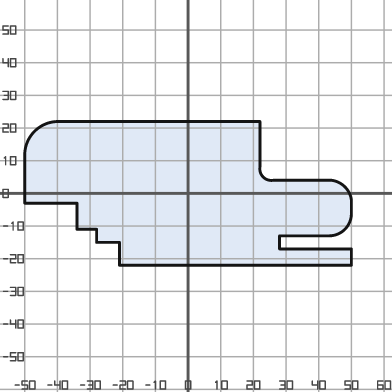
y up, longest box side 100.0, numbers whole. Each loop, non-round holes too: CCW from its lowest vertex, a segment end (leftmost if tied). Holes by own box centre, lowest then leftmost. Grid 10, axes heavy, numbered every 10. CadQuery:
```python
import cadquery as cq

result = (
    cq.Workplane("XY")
    .moveTo(-21.0, -22.0)
    .lineTo(50.0, -22.0)
    .lineTo(50.0, -17.0)
    .lineTo(28.0, -17.0)
    .lineTo(28.0, -13.0)
    .lineTo(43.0, -13.0)
    .threePointArc((48.0, -11.0), (50.0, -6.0))
    .lineTo(50.0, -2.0)
    .threePointArc((48.0, 2.0), (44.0, 4.0))
    .lineTo(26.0, 4.0)
    .threePointArc((23.0, 5.0), (22.0, 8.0))
    .lineTo(22.0, 22.0)
    .lineTo(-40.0, 22.0)
    .threePointArc((-47.0, 19.0), (-50.0, 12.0))
    .lineTo(-50.0, -3.0)
    .lineTo(-34.0, -3.0)
    .lineTo(-34.0, -11.0)
    .lineTo(-28.0, -11.0)
    .lineTo(-28.0, -15.0)
    .lineTo(-21.0, -15.0)
    .close()
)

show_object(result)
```